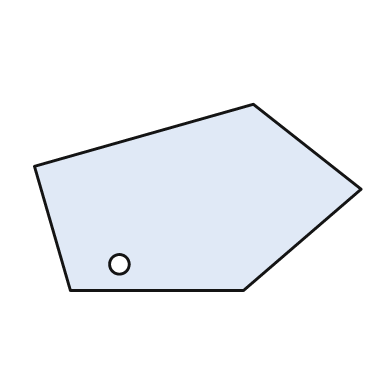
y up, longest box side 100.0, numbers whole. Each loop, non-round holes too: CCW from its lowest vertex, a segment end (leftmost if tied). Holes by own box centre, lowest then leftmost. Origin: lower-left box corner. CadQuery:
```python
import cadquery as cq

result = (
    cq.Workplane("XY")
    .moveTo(11.0, 0.0)
    .lineTo(64.0, 0.0)
    .lineTo(100.0, 31.0)
    .lineTo(67.0, 57.0)
    .lineTo(0.0, 38.0)
    .close()
    .moveTo(26.0, 8.0)
    .circle(3.0)
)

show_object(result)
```